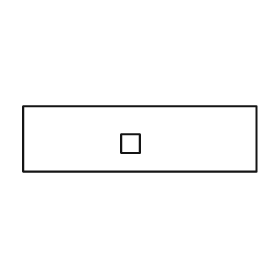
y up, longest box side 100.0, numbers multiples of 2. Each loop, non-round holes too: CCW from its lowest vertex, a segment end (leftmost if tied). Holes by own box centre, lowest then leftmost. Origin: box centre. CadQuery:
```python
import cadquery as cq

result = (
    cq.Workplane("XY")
    .moveTo(-50.0, -14.0)
    .lineTo(50.0, -14.0)
    .lineTo(50.0, 14.0)
    .lineTo(-50.0, 14.0)
    .close()
    .moveTo(-8.0, -6.0)
    .lineTo(0.0, -6.0)
    .lineTo(0.0, 2.0)
    .lineTo(-8.0, 2.0)
    .close()
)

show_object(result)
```